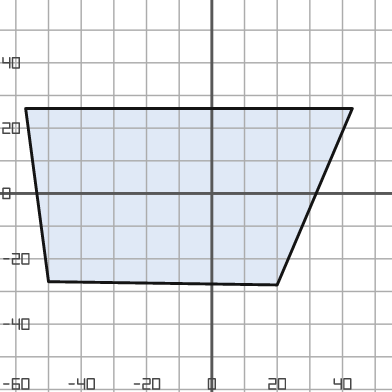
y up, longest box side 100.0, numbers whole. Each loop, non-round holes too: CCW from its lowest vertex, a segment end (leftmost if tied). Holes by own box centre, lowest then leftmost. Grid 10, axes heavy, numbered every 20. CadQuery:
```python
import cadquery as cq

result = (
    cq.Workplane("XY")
    .moveTo(20.0, -28.0)
    .lineTo(43.0, 26.0)
    .lineTo(-57.0, 26.0)
    .lineTo(-50.0, -27.0)
    .close()
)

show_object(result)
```